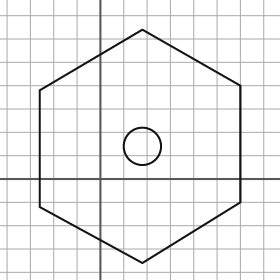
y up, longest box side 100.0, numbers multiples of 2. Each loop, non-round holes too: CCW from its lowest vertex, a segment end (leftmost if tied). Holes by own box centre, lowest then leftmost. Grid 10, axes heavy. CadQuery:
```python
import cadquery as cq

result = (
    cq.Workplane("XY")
    .moveTo(18.0, -36.0)
    .lineTo(60.0, -10.0)
    .lineTo(60.0, 40.0)
    .lineTo(18.0, 64.0)
    .lineTo(-26.0, 38.0)
    .lineTo(-26.0, -12.0)
    .close()
    .moveTo(18.0, 14.0)
    .circle(8.0)
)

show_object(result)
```